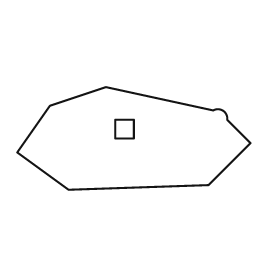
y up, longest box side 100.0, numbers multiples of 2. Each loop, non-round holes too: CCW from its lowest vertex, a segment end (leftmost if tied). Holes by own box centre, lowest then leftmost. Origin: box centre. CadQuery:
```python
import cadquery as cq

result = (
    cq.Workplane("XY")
    .moveTo(-28.0, -22.0)
    .lineTo(32.0, -20.0)
    .lineTo(50.0, -2.0)
    .lineTo(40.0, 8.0)
    .threePointArc((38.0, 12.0), (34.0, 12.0))
    .lineTo(-12.0, 22.0)
    .lineTo(-36.0, 14.0)
    .lineTo(-50.0, -6.0)
    .close()
    .moveTo(-8.0, 0.0)
    .lineTo(0.0, 0.0)
    .lineTo(0.0, 8.0)
    .lineTo(-8.0, 8.0)
    .close()
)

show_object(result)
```